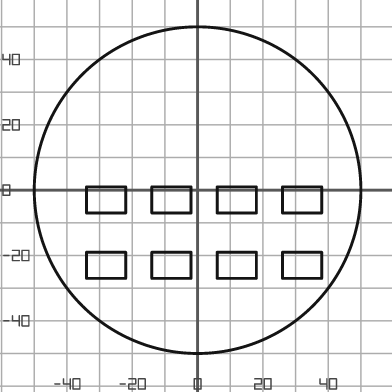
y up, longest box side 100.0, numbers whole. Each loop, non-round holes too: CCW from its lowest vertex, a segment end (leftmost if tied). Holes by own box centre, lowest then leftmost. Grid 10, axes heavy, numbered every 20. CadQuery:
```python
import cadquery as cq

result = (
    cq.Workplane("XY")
    .moveTo(0.0, 0.0)
    .circle(50.0)
    .moveTo(-34.0, -27.0)
    .lineTo(-22.0, -27.0)
    .lineTo(-22.0, -19.0)
    .lineTo(-34.0, -19.0)
    .close()
    .moveTo(-14.0, -27.0)
    .lineTo(-2.0, -27.0)
    .lineTo(-2.0, -19.0)
    .lineTo(-14.0, -19.0)
    .close()
    .moveTo(6.0, -27.0)
    .lineTo(18.0, -27.0)
    .lineTo(18.0, -19.0)
    .lineTo(6.0, -19.0)
    .close()
    .moveTo(26.0, -27.0)
    .lineTo(38.0, -27.0)
    .lineTo(38.0, -19.0)
    .lineTo(26.0, -19.0)
    .close()
    .moveTo(-34.0, -7.0)
    .lineTo(-22.0, -7.0)
    .lineTo(-22.0, 1.0)
    .lineTo(-34.0, 1.0)
    .close()
    .moveTo(-14.0, -7.0)
    .lineTo(-2.0, -7.0)
    .lineTo(-2.0, 1.0)
    .lineTo(-14.0, 1.0)
    .close()
    .moveTo(6.0, -7.0)
    .lineTo(18.0, -7.0)
    .lineTo(18.0, 1.0)
    .lineTo(6.0, 1.0)
    .close()
    .moveTo(26.0, -7.0)
    .lineTo(38.0, -7.0)
    .lineTo(38.0, 1.0)
    .lineTo(26.0, 1.0)
    .close()
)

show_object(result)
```